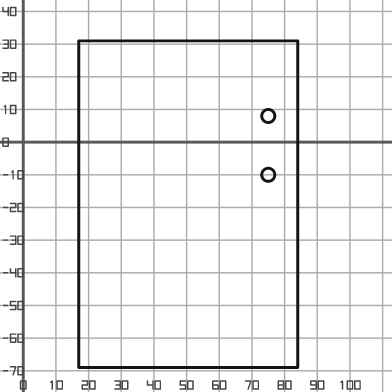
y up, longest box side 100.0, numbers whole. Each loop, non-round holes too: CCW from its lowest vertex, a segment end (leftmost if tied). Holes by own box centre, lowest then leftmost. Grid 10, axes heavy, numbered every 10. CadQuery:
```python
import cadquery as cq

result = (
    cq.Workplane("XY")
    .moveTo(17.0, -69.0)
    .lineTo(84.0, -69.0)
    .lineTo(84.0, 31.0)
    .lineTo(17.0, 31.0)
    .close()
    .moveTo(75.0, -10.0)
    .circle(2.0)
    .moveTo(75.0, 8.0)
    .circle(2.0)
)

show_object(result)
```